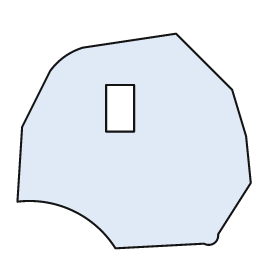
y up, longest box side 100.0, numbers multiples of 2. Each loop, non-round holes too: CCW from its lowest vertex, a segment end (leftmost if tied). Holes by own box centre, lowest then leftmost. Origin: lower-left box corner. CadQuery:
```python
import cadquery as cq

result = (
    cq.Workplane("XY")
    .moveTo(42.0, 0.0)
    .lineTo(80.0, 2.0)
    .threePointArc((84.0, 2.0), (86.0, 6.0))
    .lineTo(100.0, 28.0)
    .lineTo(98.0, 48.0)
    .lineTo(92.0, 68.0)
    .lineTo(68.0, 92.0)
    .lineTo(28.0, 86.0)
    .threePointArc((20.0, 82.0), (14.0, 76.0))
    .lineTo(2.0, 52.0)
    .lineTo(0.0, 20.0)
    .threePointArc((24.0, 16.0), (42.0, 0.0))
    .close()
    .moveTo(38.0, 50.0)
    .lineTo(50.0, 50.0)
    .lineTo(50.0, 70.0)
    .lineTo(38.0, 70.0)
    .close()
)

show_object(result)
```